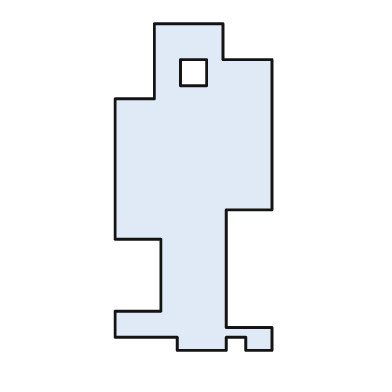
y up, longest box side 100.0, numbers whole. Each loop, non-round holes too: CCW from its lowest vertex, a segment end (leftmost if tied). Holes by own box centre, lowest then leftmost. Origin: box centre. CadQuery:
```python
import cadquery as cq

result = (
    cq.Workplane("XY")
    .moveTo(-5.0, -50.0)
    .lineTo(10.0, -50.0)
    .lineTo(10.0, -46.0)
    .lineTo(16.0, -46.0)
    .lineTo(16.0, -50.0)
    .lineTo(24.0, -50.0)
    .lineTo(24.0, -43.0)
    .lineTo(10.0, -43.0)
    .lineTo(10.0, -7.0)
    .lineTo(24.0, -7.0)
    .lineTo(24.0, 39.0)
    .lineTo(9.0, 39.0)
    .lineTo(9.0, 50.0)
    .lineTo(-12.0, 50.0)
    .lineTo(-12.0, 27.0)
    .lineTo(-24.0, 27.0)
    .lineTo(-24.0, -16.0)
    .lineTo(-10.0, -16.0)
    .lineTo(-10.0, -38.0)
    .lineTo(-24.0, -38.0)
    .lineTo(-24.0, -46.0)
    .lineTo(-5.0, -46.0)
    .close()
    .moveTo(-4.0, 31.0)
    .lineTo(4.0, 31.0)
    .lineTo(4.0, 39.0)
    .lineTo(-4.0, 39.0)
    .close()
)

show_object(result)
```